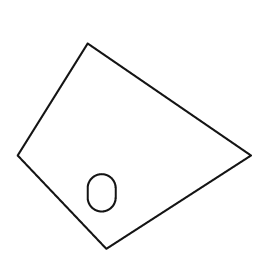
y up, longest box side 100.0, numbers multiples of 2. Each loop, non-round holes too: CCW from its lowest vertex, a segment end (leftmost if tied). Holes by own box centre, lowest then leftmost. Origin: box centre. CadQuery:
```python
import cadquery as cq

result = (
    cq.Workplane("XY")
    .moveTo(-12.0, -44.0)
    .lineTo(50.0, -4.0)
    .lineTo(-20.0, 44.0)
    .lineTo(-50.0, -4.0)
    .close()
    .moveTo(-20.0, -22.0)
    .threePointArc((-14.0, -28.0), (-8.0, -22.0))
    .lineTo(-8.0, -18.0)
    .threePointArc((-14.0, -12.0), (-20.0, -18.0))
    .close()
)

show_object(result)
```